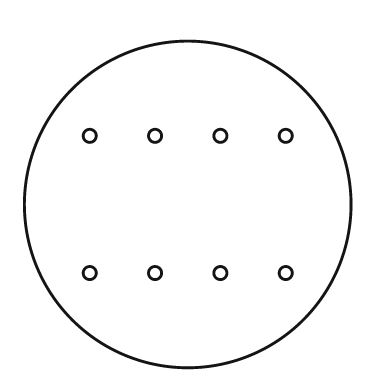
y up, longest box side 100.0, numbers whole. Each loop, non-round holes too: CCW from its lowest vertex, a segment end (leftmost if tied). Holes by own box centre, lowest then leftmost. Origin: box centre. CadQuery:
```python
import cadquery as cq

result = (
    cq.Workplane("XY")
    .moveTo(0.0, 0.0)
    .circle(50.0)
    .moveTo(-30.0, -21.0)
    .circle(2.0)
    .moveTo(-10.0, -21.0)
    .circle(2.0)
    .moveTo(10.0, -21.0)
    .circle(2.0)
    .moveTo(30.0, -21.0)
    .circle(2.0)
    .moveTo(-30.0, 21.0)
    .circle(2.0)
    .moveTo(-10.0, 21.0)
    .circle(2.0)
    .moveTo(10.0, 21.0)
    .circle(2.0)
    .moveTo(30.0, 21.0)
    .circle(2.0)
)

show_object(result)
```